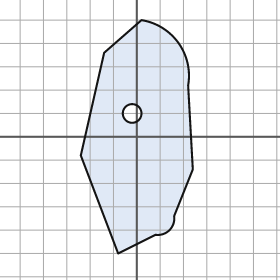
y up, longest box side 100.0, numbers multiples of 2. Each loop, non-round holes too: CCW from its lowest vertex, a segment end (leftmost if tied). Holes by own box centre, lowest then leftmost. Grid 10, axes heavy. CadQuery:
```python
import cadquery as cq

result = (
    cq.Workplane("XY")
    .moveTo(-8.0, -50.0)
    .lineTo(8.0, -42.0)
    .threePointArc((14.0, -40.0), (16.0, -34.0))
    .lineTo(24.0, -14.0)
    .lineTo(22.0, 22.0)
    .threePointArc((18.0, 40.0), (2.0, 50.0))
    .lineTo(-14.0, 36.0)
    .lineTo(-24.0, -8.0)
    .close()
    .moveTo(-2.0, 10.0)
    .circle(4.0)
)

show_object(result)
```